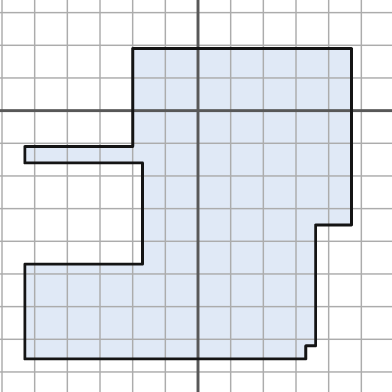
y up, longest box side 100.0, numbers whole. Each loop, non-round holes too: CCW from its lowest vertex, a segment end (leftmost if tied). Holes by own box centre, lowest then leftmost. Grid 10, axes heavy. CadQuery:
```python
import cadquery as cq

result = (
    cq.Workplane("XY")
    .moveTo(-53.0, -76.0)
    .lineTo(33.0, -76.0)
    .lineTo(33.0, -72.0)
    .lineTo(36.0, -72.0)
    .lineTo(36.0, -35.0)
    .lineTo(47.0, -35.0)
    .lineTo(47.0, 19.0)
    .lineTo(-20.0, 19.0)
    .lineTo(-20.0, -11.0)
    .lineTo(-53.0, -11.0)
    .lineTo(-53.0, -16.0)
    .lineTo(-17.0, -16.0)
    .lineTo(-17.0, -47.0)
    .lineTo(-53.0, -47.0)
    .close()
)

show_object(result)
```